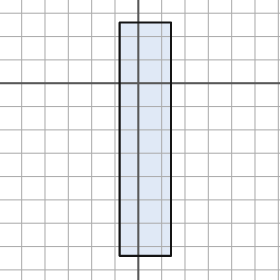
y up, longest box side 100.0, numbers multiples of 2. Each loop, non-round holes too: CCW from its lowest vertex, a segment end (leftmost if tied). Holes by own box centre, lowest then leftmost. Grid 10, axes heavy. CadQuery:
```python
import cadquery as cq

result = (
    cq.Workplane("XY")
    .moveTo(-8.0, -74.0)
    .lineTo(14.0, -74.0)
    .lineTo(14.0, 26.0)
    .lineTo(-8.0, 26.0)
    .close()
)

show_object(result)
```